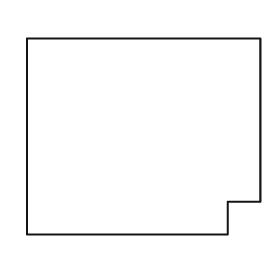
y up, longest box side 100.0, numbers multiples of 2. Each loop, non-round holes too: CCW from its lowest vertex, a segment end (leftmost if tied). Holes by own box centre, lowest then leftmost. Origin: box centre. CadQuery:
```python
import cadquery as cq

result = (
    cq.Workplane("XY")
    .moveTo(-50.0, -42.0)
    .lineTo(36.0, -42.0)
    .lineTo(36.0, -28.0)
    .lineTo(50.0, -28.0)
    .lineTo(50.0, 42.0)
    .lineTo(-50.0, 42.0)
    .close()
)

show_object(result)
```